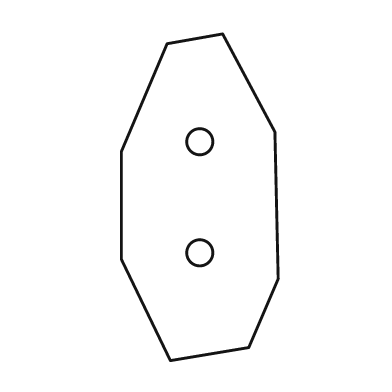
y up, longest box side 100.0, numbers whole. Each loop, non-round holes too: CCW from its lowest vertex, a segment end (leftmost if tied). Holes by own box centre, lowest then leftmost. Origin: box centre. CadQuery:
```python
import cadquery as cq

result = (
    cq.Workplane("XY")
    .moveTo(-9.0, -50.0)
    .lineTo(15.0, -46.0)
    .lineTo(24.0, -25.0)
    .lineTo(23.0, 20.0)
    .lineTo(7.0, 50.0)
    .lineTo(-10.0, 47.0)
    .lineTo(-24.0, 14.0)
    .lineTo(-24.0, -19.0)
    .close()
    .moveTo(0.0, -17.0)
    .circle(4.0)
    .moveTo(0.0, 17.0)
    .circle(4.0)
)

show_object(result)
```